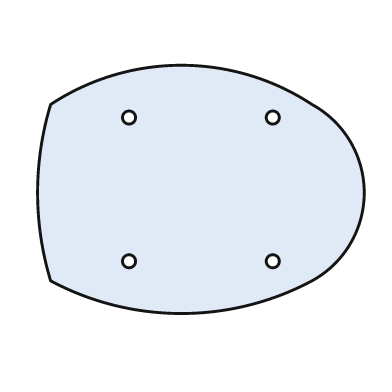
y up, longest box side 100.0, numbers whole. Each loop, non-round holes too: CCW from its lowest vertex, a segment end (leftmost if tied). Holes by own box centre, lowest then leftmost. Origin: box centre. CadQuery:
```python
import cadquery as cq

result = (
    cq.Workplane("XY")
    .moveTo(-46.0, -28.0)
    .threePointArc((-6.0, -38.0), (34.0, -28.0))
    .threePointArc((50.0, -1.0), (34.0, 26.0))
    .threePointArc((-6.0, 38.0), (-46.0, 26.0))
    .threePointArc((-50.0, -1.0), (-46.0, -28.0))
    .close()
    .moveTo(-22.0, -22.0)
    .circle(2.0)
    .moveTo(22.0, -22.0)
    .circle(2.0)
    .moveTo(-22.0, 22.0)
    .circle(2.0)
    .moveTo(22.0, 22.0)
    .circle(2.0)
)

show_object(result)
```